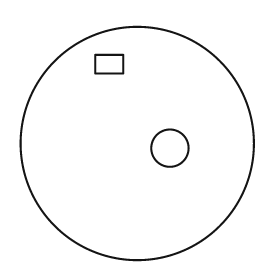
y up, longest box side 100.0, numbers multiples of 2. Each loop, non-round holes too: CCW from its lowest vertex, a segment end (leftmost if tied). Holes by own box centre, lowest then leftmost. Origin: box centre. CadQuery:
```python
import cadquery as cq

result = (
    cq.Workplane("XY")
    .moveTo(0.0, 0.0)
    .circle(50.0)
    .moveTo(14.0, -2.0)
    .circle(8.0)
    .moveTo(-18.0, 30.0)
    .lineTo(-6.0, 30.0)
    .lineTo(-6.0, 38.0)
    .lineTo(-18.0, 38.0)
    .close()
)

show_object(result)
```